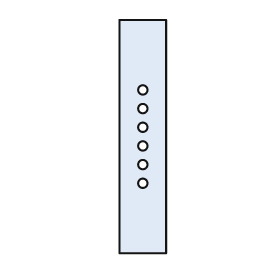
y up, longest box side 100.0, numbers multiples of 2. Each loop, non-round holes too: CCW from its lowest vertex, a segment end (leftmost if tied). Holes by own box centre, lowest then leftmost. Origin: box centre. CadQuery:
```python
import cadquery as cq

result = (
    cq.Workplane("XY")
    .moveTo(-10.0, -50.0)
    .lineTo(10.0, -50.0)
    .lineTo(10.0, 50.0)
    .lineTo(-10.0, 50.0)
    .close()
    .moveTo(0.0, -20.0)
    .circle(2.0)
    .moveTo(0.0, -12.0)
    .circle(2.0)
    .moveTo(0.0, -4.0)
    .circle(2.0)
    .moveTo(0.0, 4.0)
    .circle(2.0)
    .moveTo(0.0, 12.0)
    .circle(2.0)
    .moveTo(0.0, 20.0)
    .circle(2.0)
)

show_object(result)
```